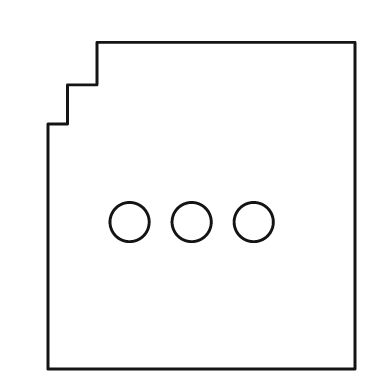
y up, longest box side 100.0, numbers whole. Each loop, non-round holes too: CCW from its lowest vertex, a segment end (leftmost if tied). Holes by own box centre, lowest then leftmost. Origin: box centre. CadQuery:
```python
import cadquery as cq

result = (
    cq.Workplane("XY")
    .moveTo(-47.0, -50.0)
    .lineTo(47.0, -50.0)
    .lineTo(47.0, 50.0)
    .lineTo(-32.0, 50.0)
    .lineTo(-32.0, 37.0)
    .lineTo(-41.0, 37.0)
    .lineTo(-41.0, 25.0)
    .lineTo(-47.0, 25.0)
    .close()
    .moveTo(-22.0, -5.0)
    .circle(6.0)
    .moveTo(-3.0, -5.0)
    .circle(6.0)
    .moveTo(16.0, -5.0)
    .circle(6.0)
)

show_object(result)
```